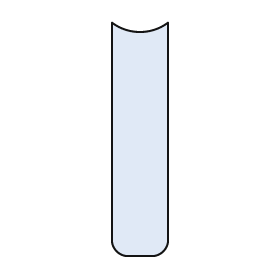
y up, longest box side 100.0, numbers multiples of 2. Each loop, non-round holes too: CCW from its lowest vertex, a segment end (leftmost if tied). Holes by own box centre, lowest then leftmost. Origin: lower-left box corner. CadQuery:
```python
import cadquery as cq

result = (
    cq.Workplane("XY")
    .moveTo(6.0, 0.0)
    .lineTo(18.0, 0.0)
    .threePointArc((22.0, 2.0), (24.0, 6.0))
    .lineTo(24.0, 100.0)
    .threePointArc((12.0, 96.0), (0.0, 100.0))
    .lineTo(0.0, 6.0)
    .threePointArc((2.0, 2.0), (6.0, 0.0))
    .close()
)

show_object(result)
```